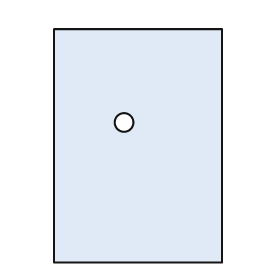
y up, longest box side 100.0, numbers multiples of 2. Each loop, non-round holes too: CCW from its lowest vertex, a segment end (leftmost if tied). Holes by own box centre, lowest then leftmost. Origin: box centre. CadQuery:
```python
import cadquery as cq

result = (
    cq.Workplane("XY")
    .moveTo(-36.0, -50.0)
    .lineTo(36.0, -50.0)
    .lineTo(36.0, 50.0)
    .lineTo(-36.0, 50.0)
    .close()
    .moveTo(-6.0, 10.0)
    .circle(4.0)
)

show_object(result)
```